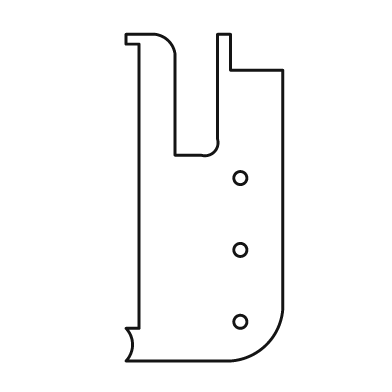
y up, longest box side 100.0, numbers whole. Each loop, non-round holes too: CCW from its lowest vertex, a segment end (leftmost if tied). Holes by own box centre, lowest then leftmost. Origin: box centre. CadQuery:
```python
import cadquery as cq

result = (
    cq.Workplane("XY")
    .moveTo(-24.0, -50.0)
    .lineTo(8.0, -50.0)
    .threePointArc((19.0, -45.0), (24.0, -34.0))
    .lineTo(24.0, 39.0)
    .lineTo(8.0, 39.0)
    .lineTo(8.0, 50.0)
    .lineTo(4.0, 50.0)
    .lineTo(4.0, 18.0)
    .threePointArc((3.0, 14.0), (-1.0, 13.0))
    .lineTo(-9.0, 13.0)
    .lineTo(-9.0, 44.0)
    .threePointArc((-11.0, 48.0), (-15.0, 50.0))
    .lineTo(-24.0, 50.0)
    .lineTo(-24.0, 47.0)
    .lineTo(-20.0, 47.0)
    .lineTo(-20.0, -40.0)
    .lineTo(-24.0, -40.0)
    .threePointArc((-22.0, -45.0), (-24.0, -50.0))
    .close()
    .moveTo(11.0, -38.0)
    .circle(2.0)
    .moveTo(11.0, -16.0)
    .circle(2.0)
    .moveTo(11.0, 6.0)
    .circle(2.0)
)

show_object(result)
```